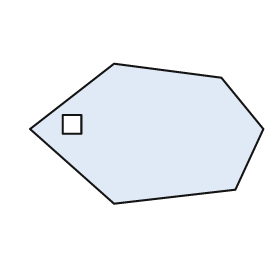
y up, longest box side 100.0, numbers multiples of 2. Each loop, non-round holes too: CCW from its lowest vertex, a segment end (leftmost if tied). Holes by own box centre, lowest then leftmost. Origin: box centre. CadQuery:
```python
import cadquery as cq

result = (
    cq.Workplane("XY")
    .moveTo(-14.0, -30.0)
    .lineTo(38.0, -24.0)
    .lineTo(50.0, 2.0)
    .lineTo(32.0, 24.0)
    .lineTo(-14.0, 30.0)
    .lineTo(-50.0, 2.0)
    .close()
    .moveTo(-36.0, 0.0)
    .lineTo(-28.0, 0.0)
    .lineTo(-28.0, 8.0)
    .lineTo(-36.0, 8.0)
    .close()
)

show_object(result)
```